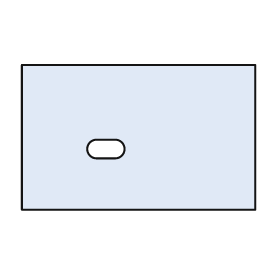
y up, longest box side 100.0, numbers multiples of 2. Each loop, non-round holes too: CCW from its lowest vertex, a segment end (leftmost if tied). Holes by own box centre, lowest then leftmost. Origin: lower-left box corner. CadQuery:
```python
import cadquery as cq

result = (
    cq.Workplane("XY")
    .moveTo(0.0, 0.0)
    .lineTo(100.0, 0.0)
    .lineTo(100.0, 62.0)
    .lineTo(0.0, 62.0)
    .close()
    .moveTo(32.0, 22.0)
    .lineTo(40.0, 22.0)
    .threePointArc((44.0, 26.0), (40.0, 30.0))
    .lineTo(32.0, 30.0)
    .threePointArc((28.0, 26.0), (32.0, 22.0))
    .close()
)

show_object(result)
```